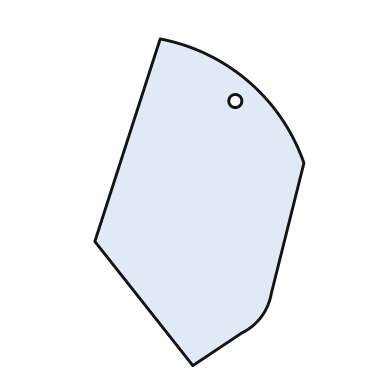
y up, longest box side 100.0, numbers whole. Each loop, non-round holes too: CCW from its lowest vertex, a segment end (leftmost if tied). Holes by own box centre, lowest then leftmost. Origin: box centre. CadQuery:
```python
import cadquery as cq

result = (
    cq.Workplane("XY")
    .moveTo(-2.0, -50.0)
    .lineTo(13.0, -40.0)
    .threePointArc((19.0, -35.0), (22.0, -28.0))
    .lineTo(32.0, 12.0)
    .threePointArc((15.0, 37.0), (-12.0, 50.0))
    .lineTo(-32.0, -12.0)
    .close()
    .moveTo(11.0, 31.0)
    .circle(2.0)
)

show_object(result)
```